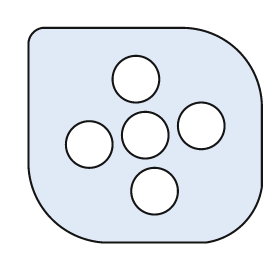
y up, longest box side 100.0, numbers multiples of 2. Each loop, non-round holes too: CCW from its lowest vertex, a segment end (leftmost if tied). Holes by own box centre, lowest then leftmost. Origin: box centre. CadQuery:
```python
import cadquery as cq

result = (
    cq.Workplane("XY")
    .moveTo(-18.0, -46.0)
    .lineTo(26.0, -46.0)
    .threePointArc((42.0, -38.0), (50.0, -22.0))
    .lineTo(50.0, 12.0)
    .threePointArc((40.0, 36.0), (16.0, 46.0))
    .lineTo(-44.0, 46.0)
    .threePointArc((-48.0, 44.0), (-50.0, 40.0))
    .lineTo(-50.0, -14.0)
    .threePointArc((-40.0, -36.0), (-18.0, -46.0))
    .close()
    .moveTo(4.0, -24.0)
    .circle(10.0)
    .moveTo(-24.0, -4.0)
    .circle(10.0)
    .moveTo(0.0, 0.0)
    .circle(10.0)
    .moveTo(24.0, 4.0)
    .circle(10.0)
    .moveTo(-4.0, 24.0)
    .circle(10.0)
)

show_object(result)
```